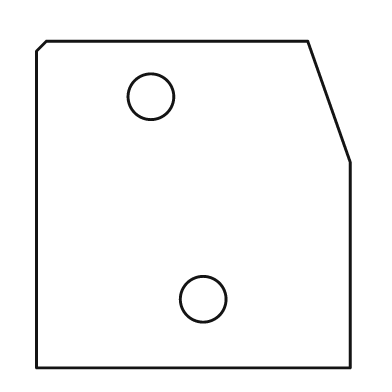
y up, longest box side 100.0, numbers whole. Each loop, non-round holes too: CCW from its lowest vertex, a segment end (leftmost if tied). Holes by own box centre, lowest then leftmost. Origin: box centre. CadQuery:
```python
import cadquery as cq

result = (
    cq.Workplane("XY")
    .moveTo(-48.0, -50.0)
    .lineTo(48.0, -50.0)
    .lineTo(48.0, 13.0)
    .lineTo(35.0, 50.0)
    .lineTo(-45.0, 50.0)
    .lineTo(-48.0, 47.0)
    .close()
    .moveTo(3.0, -29.0)
    .circle(7.0)
    .moveTo(-13.0, 33.0)
    .circle(7.0)
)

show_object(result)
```